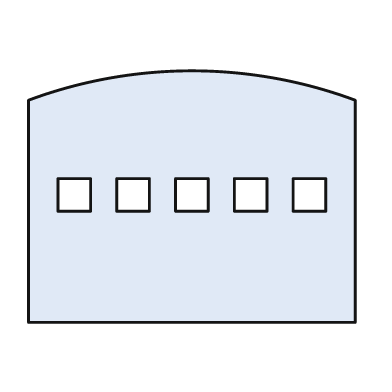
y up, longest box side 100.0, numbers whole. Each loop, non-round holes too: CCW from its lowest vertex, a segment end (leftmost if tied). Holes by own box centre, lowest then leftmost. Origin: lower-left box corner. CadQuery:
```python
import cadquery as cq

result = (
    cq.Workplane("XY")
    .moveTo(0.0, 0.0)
    .lineTo(100.0, 0.0)
    .lineTo(100.0, 68.0)
    .threePointArc((50.0, 77.0), (0.0, 68.0))
    .close()
    .moveTo(9.0, 34.0)
    .lineTo(19.0, 34.0)
    .lineTo(19.0, 44.0)
    .lineTo(9.0, 44.0)
    .close()
    .moveTo(27.0, 34.0)
    .lineTo(37.0, 34.0)
    .lineTo(37.0, 44.0)
    .lineTo(27.0, 44.0)
    .close()
    .moveTo(45.0, 34.0)
    .lineTo(55.0, 34.0)
    .lineTo(55.0, 44.0)
    .lineTo(45.0, 44.0)
    .close()
    .moveTo(63.0, 34.0)
    .lineTo(73.0, 34.0)
    .lineTo(73.0, 44.0)
    .lineTo(63.0, 44.0)
    .close()
    .moveTo(81.0, 34.0)
    .lineTo(91.0, 34.0)
    .lineTo(91.0, 44.0)
    .lineTo(81.0, 44.0)
    .close()
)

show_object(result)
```